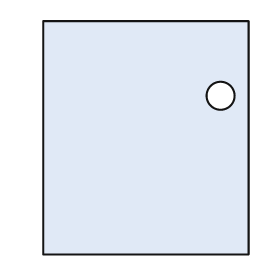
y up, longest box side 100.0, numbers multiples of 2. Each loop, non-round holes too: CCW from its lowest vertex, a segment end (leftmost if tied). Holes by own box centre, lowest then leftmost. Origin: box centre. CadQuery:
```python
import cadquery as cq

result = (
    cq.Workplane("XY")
    .moveTo(-44.0, -50.0)
    .lineTo(44.0, -50.0)
    .lineTo(44.0, 50.0)
    .lineTo(-44.0, 50.0)
    .close()
    .moveTo(32.0, 18.0)
    .circle(6.0)
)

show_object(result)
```